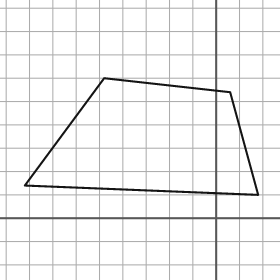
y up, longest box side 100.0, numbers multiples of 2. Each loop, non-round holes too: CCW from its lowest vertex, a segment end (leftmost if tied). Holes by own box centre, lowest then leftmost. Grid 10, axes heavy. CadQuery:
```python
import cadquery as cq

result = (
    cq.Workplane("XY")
    .moveTo(18.0, 10.0)
    .lineTo(6.0, 54.0)
    .lineTo(-48.0, 60.0)
    .lineTo(-82.0, 14.0)
    .close()
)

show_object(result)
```